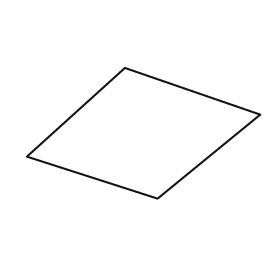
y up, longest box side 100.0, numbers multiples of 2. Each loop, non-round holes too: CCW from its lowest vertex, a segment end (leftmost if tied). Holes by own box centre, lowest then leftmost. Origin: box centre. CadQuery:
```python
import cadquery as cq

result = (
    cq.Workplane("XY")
    .moveTo(6.0, -28.0)
    .lineTo(50.0, 8.0)
    .lineTo(-8.0, 28.0)
    .lineTo(-50.0, -10.0)
    .close()
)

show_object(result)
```